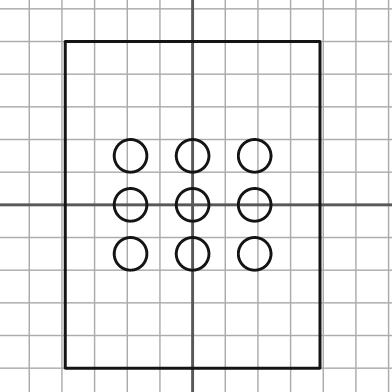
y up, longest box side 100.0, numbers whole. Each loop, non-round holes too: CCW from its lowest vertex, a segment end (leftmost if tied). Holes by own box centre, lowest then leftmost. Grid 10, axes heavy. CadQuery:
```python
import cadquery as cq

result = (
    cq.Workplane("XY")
    .moveTo(-39.0, -50.0)
    .lineTo(39.0, -50.0)
    .lineTo(39.0, 50.0)
    .lineTo(-39.0, 50.0)
    .close()
    .moveTo(-19.0, -15.0)
    .circle(5.0)
    .moveTo(0.0, -15.0)
    .circle(5.0)
    .moveTo(19.0, -15.0)
    .circle(5.0)
    .moveTo(-19.0, 0.0)
    .circle(5.0)
    .moveTo(0.0, 0.0)
    .circle(5.0)
    .moveTo(19.0, 0.0)
    .circle(5.0)
    .moveTo(-19.0, 15.0)
    .circle(5.0)
    .moveTo(0.0, 15.0)
    .circle(5.0)
    .moveTo(19.0, 15.0)
    .circle(5.0)
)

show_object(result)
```